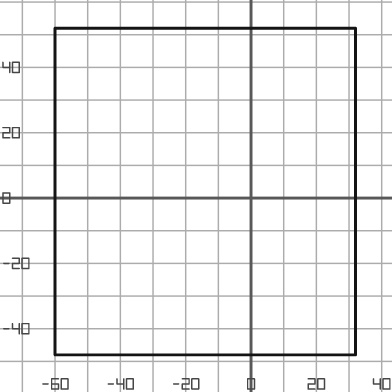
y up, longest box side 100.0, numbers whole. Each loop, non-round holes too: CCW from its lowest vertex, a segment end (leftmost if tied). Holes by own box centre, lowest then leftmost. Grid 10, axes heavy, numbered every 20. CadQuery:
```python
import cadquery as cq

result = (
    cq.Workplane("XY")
    .moveTo(-60.0, -48.0)
    .lineTo(32.0, -48.0)
    .lineTo(32.0, 52.0)
    .lineTo(-60.0, 52.0)
    .close()
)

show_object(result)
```